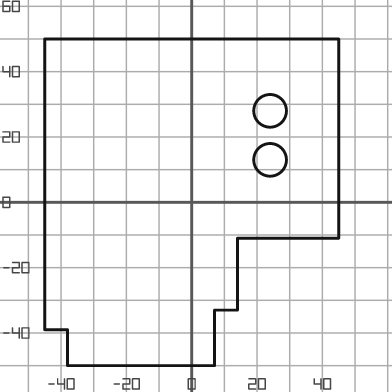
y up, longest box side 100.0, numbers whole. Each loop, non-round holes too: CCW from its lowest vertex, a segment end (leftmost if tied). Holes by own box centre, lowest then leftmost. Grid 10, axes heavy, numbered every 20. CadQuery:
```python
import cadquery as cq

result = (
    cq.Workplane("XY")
    .moveTo(-38.0, -50.0)
    .lineTo(7.0, -50.0)
    .lineTo(7.0, -33.0)
    .lineTo(14.0, -33.0)
    .lineTo(14.0, -11.0)
    .lineTo(45.0, -11.0)
    .lineTo(45.0, 50.0)
    .lineTo(-45.0, 50.0)
    .lineTo(-45.0, -39.0)
    .lineTo(-38.0, -39.0)
    .close()
    .moveTo(24.0, 13.0)
    .circle(5.0)
    .moveTo(24.0, 28.0)
    .circle(5.0)
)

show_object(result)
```